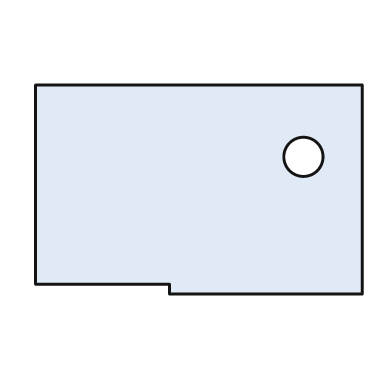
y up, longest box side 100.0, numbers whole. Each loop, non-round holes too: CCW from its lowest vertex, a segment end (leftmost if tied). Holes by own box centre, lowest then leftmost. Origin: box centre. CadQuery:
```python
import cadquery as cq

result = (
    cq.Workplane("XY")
    .moveTo(-9.0, -32.0)
    .lineTo(50.0, -32.0)
    .lineTo(50.0, 32.0)
    .lineTo(-50.0, 32.0)
    .lineTo(-50.0, -29.0)
    .lineTo(-9.0, -29.0)
    .close()
    .moveTo(32.0, 10.0)
    .circle(6.0)
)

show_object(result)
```